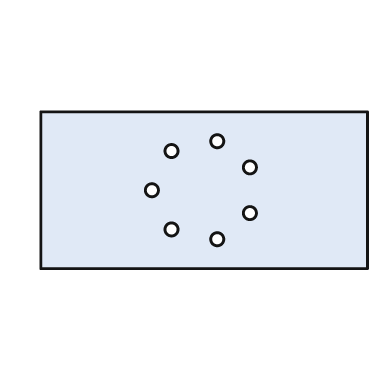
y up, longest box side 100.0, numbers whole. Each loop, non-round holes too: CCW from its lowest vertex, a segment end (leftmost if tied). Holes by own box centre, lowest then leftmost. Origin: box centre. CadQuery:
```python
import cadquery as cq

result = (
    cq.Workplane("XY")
    .moveTo(-50.0, -24.0)
    .lineTo(50.0, -24.0)
    .lineTo(50.0, 24.0)
    .lineTo(-50.0, 24.0)
    .close()
    .moveTo(4.0, -15.0)
    .circle(2.0)
    .moveTo(-10.0, -12.0)
    .circle(2.0)
    .moveTo(14.0, -7.0)
    .circle(2.0)
    .moveTo(-16.0, 0.0)
    .circle(2.0)
    .moveTo(14.0, 7.0)
    .circle(2.0)
    .moveTo(-10.0, 12.0)
    .circle(2.0)
    .moveTo(4.0, 15.0)
    .circle(2.0)
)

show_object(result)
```